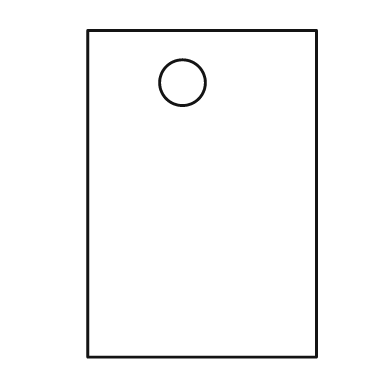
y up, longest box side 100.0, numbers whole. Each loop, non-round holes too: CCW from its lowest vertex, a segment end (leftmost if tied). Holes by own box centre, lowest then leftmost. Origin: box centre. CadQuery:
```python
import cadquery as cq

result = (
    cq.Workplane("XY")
    .moveTo(-35.0, -50.0)
    .lineTo(35.0, -50.0)
    .lineTo(35.0, 50.0)
    .lineTo(-35.0, 50.0)
    .close()
    .moveTo(-6.0, 34.0)
    .circle(7.0)
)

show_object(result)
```